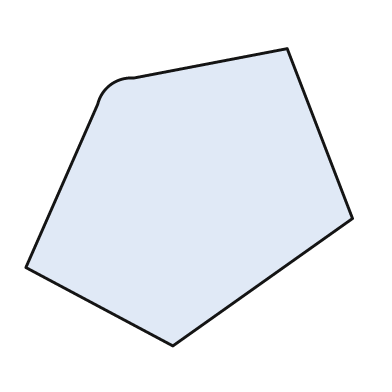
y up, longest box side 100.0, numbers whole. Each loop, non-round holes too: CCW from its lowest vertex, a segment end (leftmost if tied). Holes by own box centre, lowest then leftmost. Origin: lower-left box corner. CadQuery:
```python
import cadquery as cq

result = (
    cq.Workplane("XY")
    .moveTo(45.0, 0.0)
    .lineTo(100.0, 39.0)
    .lineTo(80.0, 91.0)
    .lineTo(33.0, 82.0)
    .threePointArc((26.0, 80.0), (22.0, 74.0))
    .lineTo(0.0, 24.0)
    .close()
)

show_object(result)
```